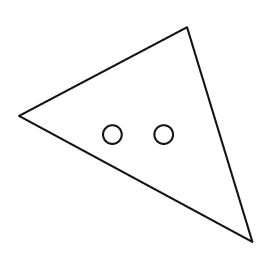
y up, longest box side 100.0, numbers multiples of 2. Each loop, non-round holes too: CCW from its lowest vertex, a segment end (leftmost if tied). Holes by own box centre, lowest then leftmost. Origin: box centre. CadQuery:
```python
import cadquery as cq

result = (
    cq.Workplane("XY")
    .moveTo(50.0, -46.0)
    .lineTo(22.0, 46.0)
    .lineTo(-50.0, 8.0)
    .close()
    .moveTo(-10.0, 0.0)
    .circle(4.0)
    .moveTo(12.0, 0.0)
    .circle(4.0)
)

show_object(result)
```